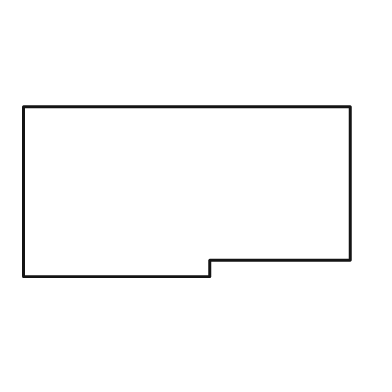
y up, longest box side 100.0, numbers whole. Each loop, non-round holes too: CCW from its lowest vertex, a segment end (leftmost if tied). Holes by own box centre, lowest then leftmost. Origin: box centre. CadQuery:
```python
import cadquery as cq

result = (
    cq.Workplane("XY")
    .moveTo(-50.0, -26.0)
    .lineTo(7.0, -26.0)
    .lineTo(7.0, -21.0)
    .lineTo(50.0, -21.0)
    .lineTo(50.0, 26.0)
    .lineTo(-50.0, 26.0)
    .close()
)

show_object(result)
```